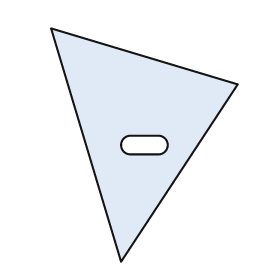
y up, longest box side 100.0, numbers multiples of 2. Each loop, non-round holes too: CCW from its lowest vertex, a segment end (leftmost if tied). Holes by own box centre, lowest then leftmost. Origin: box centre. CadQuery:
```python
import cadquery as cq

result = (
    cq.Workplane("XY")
    .moveTo(-10.0, -50.0)
    .lineTo(40.0, 26.0)
    .lineTo(-40.0, 50.0)
    .close()
    .moveTo(-6.0, -4.0)
    .lineTo(6.0, -4.0)
    .threePointArc((10.0, 0.0), (6.0, 4.0))
    .lineTo(-6.0, 4.0)
    .threePointArc((-10.0, 0.0), (-6.0, -4.0))
    .close()
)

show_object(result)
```